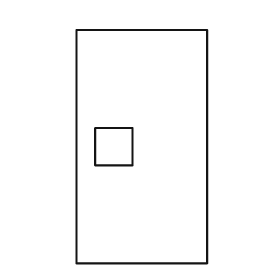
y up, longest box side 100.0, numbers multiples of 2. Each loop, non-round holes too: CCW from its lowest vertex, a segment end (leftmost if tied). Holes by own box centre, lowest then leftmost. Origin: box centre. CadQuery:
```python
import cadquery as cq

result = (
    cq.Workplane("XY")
    .moveTo(-28.0, -50.0)
    .lineTo(28.0, -50.0)
    .lineTo(28.0, 50.0)
    .lineTo(-28.0, 50.0)
    .close()
    .moveTo(-20.0, -8.0)
    .lineTo(-4.0, -8.0)
    .lineTo(-4.0, 8.0)
    .lineTo(-20.0, 8.0)
    .close()
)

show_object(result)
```